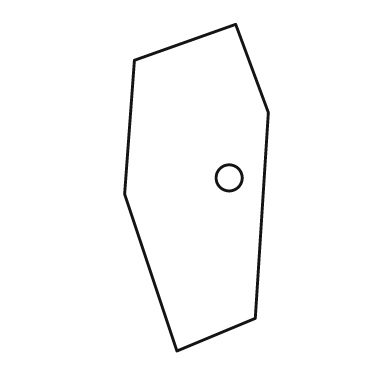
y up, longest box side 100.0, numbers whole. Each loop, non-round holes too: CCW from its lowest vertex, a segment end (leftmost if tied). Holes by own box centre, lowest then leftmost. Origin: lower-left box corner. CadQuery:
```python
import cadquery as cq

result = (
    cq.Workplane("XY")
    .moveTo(16.0, 0.0)
    .lineTo(40.0, 10.0)
    .lineTo(44.0, 73.0)
    .lineTo(34.0, 100.0)
    .lineTo(3.0, 89.0)
    .lineTo(0.0, 48.0)
    .close()
    .moveTo(32.0, 53.0)
    .circle(4.0)
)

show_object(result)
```